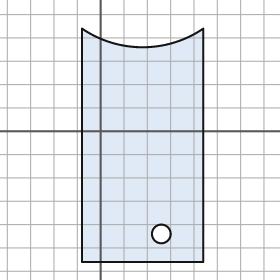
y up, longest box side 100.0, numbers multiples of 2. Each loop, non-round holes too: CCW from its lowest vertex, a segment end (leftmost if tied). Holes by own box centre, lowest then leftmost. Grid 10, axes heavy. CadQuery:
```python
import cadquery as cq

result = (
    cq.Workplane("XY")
    .moveTo(-8.0, -56.0)
    .lineTo(44.0, -56.0)
    .lineTo(44.0, 44.0)
    .threePointArc((18.0, 36.0), (-8.0, 44.0))
    .close()
    .moveTo(26.0, -44.0)
    .circle(4.0)
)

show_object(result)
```